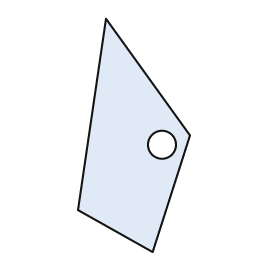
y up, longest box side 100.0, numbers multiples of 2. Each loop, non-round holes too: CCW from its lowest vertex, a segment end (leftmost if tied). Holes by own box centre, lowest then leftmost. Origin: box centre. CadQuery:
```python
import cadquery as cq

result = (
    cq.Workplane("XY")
    .moveTo(8.0, -50.0)
    .lineTo(24.0, 0.0)
    .lineTo(-12.0, 50.0)
    .lineTo(-24.0, -32.0)
    .close()
    .moveTo(12.0, -4.0)
    .circle(6.0)
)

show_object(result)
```